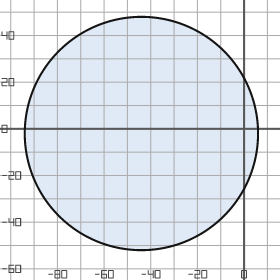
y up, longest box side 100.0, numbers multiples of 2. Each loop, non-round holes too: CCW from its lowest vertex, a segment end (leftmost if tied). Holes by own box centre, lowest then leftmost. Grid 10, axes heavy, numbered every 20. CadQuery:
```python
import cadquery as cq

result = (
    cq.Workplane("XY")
    .moveTo(-44.0, -2.0)
    .circle(50.0)
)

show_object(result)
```